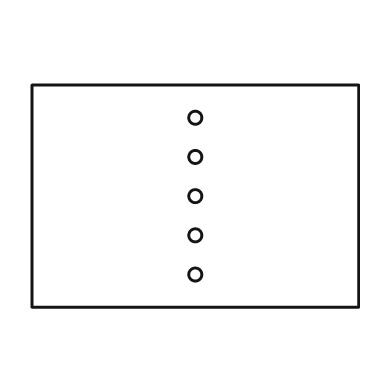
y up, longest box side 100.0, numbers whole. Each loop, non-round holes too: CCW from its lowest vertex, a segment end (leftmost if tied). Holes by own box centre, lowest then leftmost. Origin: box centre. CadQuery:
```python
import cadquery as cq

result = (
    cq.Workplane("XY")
    .moveTo(-50.0, -34.0)
    .lineTo(50.0, -34.0)
    .lineTo(50.0, 34.0)
    .lineTo(-50.0, 34.0)
    .close()
    .moveTo(0.0, -24.0)
    .circle(2.0)
    .moveTo(0.0, -12.0)
    .circle(2.0)
    .moveTo(0.0, 0.0)
    .circle(2.0)
    .moveTo(0.0, 12.0)
    .circle(2.0)
    .moveTo(0.0, 24.0)
    .circle(2.0)
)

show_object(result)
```